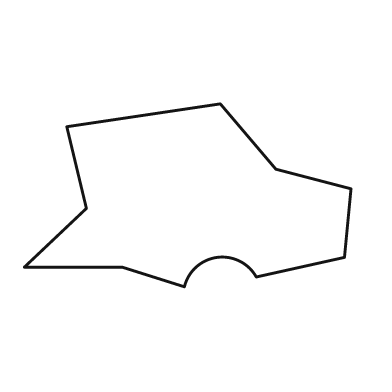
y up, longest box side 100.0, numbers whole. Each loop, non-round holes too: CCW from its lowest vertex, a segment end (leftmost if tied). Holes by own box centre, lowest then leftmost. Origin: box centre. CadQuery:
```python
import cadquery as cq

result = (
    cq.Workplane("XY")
    .moveTo(-1.0, -28.0)
    .threePointArc((9.0, -19.0), (21.0, -25.0))
    .lineTo(48.0, -19.0)
    .lineTo(50.0, 2.0)
    .lineTo(27.0, 8.0)
    .lineTo(10.0, 28.0)
    .lineTo(-37.0, 21.0)
    .lineTo(-31.0, -4.0)
    .lineTo(-50.0, -22.0)
    .lineTo(-20.0, -22.0)
    .close()
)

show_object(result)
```